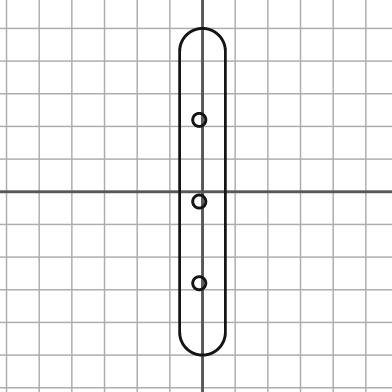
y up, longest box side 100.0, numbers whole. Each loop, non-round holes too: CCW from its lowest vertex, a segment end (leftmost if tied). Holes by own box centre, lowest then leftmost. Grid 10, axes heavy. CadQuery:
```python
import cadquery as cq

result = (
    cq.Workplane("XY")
    .moveTo(-7.0, -43.0)
    .threePointArc((0.0, -50.0), (7.0, -43.0))
    .lineTo(7.0, 43.0)
    .threePointArc((0.0, 50.0), (-7.0, 43.0))
    .close()
    .moveTo(-1.0, -28.0)
    .circle(2.0)
    .moveTo(-1.0, -3.0)
    .circle(2.0)
    .moveTo(-1.0, 22.0)
    .circle(2.0)
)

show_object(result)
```